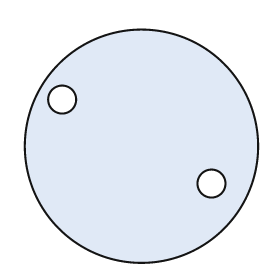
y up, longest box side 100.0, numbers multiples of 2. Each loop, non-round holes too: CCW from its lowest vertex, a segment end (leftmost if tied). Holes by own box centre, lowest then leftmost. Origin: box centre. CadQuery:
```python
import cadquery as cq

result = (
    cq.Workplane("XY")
    .moveTo(0.0, 0.0)
    .circle(50.0)
    .moveTo(30.0, -16.0)
    .circle(6.0)
    .moveTo(-34.0, 20.0)
    .circle(6.0)
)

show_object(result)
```